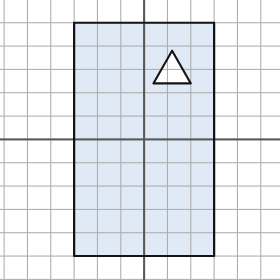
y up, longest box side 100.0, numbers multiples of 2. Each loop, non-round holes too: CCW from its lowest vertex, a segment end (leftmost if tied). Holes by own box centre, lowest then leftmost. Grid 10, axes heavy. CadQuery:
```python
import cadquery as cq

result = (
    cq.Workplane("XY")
    .moveTo(-30.0, -50.0)
    .lineTo(30.0, -50.0)
    .lineTo(30.0, 50.0)
    .lineTo(-30.0, 50.0)
    .close()
    .moveTo(4.0, 24.0)
    .lineTo(20.0, 24.0)
    .lineTo(12.0, 38.0)
    .close()
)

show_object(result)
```